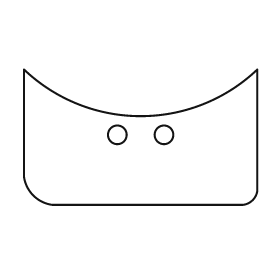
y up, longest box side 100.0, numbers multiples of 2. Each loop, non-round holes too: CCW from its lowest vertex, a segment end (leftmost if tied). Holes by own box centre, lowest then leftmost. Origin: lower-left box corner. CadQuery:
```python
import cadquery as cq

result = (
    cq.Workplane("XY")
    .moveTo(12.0, 0.0)
    .lineTo(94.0, 0.0)
    .threePointArc((98.0, 2.0), (100.0, 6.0))
    .lineTo(100.0, 58.0)
    .threePointArc((50.0, 38.0), (0.0, 58.0))
    .lineTo(0.0, 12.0)
    .threePointArc((4.0, 4.0), (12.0, 0.0))
    .close()
    .moveTo(40.0, 30.0)
    .circle(4.0)
    .moveTo(60.0, 30.0)
    .circle(4.0)
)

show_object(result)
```